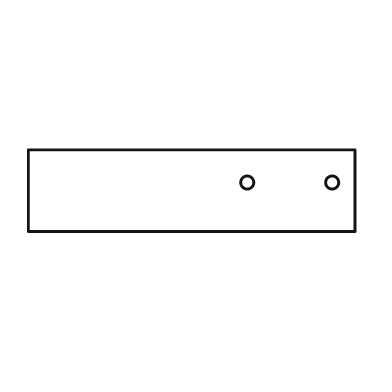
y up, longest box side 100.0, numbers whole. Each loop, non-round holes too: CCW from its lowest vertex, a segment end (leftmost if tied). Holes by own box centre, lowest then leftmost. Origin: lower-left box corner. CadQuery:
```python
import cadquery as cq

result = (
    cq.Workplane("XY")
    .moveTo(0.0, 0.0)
    .lineTo(100.0, 0.0)
    .lineTo(100.0, 25.0)
    .lineTo(0.0, 25.0)
    .close()
    .moveTo(67.0, 15.0)
    .circle(2.0)
    .moveTo(93.0, 15.0)
    .circle(2.0)
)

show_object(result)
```